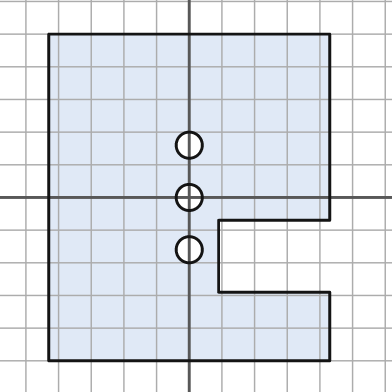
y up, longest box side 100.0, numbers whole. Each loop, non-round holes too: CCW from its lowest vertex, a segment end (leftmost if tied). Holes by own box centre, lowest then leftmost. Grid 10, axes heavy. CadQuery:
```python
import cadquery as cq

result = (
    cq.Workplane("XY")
    .moveTo(-43.0, -50.0)
    .lineTo(43.0, -50.0)
    .lineTo(43.0, -29.0)
    .lineTo(9.0, -29.0)
    .lineTo(9.0, -7.0)
    .lineTo(43.0, -7.0)
    .lineTo(43.0, 50.0)
    .lineTo(-43.0, 50.0)
    .close()
    .moveTo(0.0, -16.0)
    .circle(4.0)
    .moveTo(0.0, 0.0)
    .circle(4.0)
    .moveTo(0.0, 16.0)
    .circle(4.0)
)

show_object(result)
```